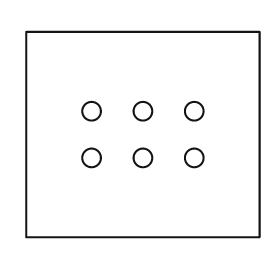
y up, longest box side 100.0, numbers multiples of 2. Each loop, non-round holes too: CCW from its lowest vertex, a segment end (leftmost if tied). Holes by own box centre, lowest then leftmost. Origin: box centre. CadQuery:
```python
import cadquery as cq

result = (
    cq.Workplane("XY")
    .moveTo(-50.0, -44.0)
    .lineTo(50.0, -44.0)
    .lineTo(50.0, 44.0)
    .lineTo(-50.0, 44.0)
    .close()
    .moveTo(-22.0, -10.0)
    .circle(4.0)
    .moveTo(0.0, -10.0)
    .circle(4.0)
    .moveTo(22.0, -10.0)
    .circle(4.0)
    .moveTo(-22.0, 10.0)
    .circle(4.0)
    .moveTo(0.0, 10.0)
    .circle(4.0)
    .moveTo(22.0, 10.0)
    .circle(4.0)
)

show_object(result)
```